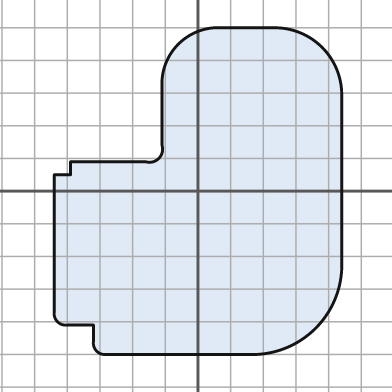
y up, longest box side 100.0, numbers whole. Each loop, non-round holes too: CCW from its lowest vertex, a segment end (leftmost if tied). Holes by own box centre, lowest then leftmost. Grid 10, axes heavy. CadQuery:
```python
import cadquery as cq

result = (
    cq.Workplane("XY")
    .moveTo(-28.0, -50.0)
    .lineTo(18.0, -50.0)
    .threePointArc((36.0, -42.0), (44.0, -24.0))
    .lineTo(44.0, 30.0)
    .threePointArc((38.0, 44.0), (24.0, 50.0))
    .lineTo(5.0, 50.0)
    .threePointArc((-6.0, 45.0), (-11.0, 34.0))
    .lineTo(-11.0, 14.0)
    .threePointArc((-12.0, 10.0), (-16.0, 9.0))
    .lineTo(-39.0, 9.0)
    .lineTo(-39.0, 5.0)
    .lineTo(-44.0, 5.0)
    .lineTo(-44.0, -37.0)
    .threePointArc((-43.0, -40.0), (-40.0, -41.0))
    .lineTo(-32.0, -41.0)
    .lineTo(-32.0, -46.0)
    .threePointArc((-31.0, -49.0), (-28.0, -50.0))
    .close()
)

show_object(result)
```